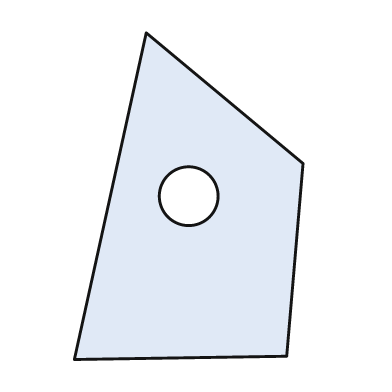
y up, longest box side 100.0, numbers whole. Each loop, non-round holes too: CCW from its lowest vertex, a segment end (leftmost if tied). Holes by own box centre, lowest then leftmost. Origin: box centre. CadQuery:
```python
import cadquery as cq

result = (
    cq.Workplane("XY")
    .moveTo(-35.0, -50.0)
    .lineTo(30.0, -49.0)
    .lineTo(35.0, 10.0)
    .lineTo(-13.0, 50.0)
    .close()
    .moveTo(0.0, 0.0)
    .circle(9.0)
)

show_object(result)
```